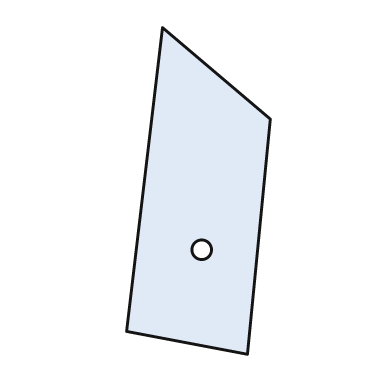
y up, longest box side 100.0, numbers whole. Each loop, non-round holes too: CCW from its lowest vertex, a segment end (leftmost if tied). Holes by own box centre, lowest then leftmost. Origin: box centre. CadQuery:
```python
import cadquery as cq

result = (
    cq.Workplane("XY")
    .moveTo(15.0, -50.0)
    .lineTo(22.0, 22.0)
    .lineTo(-11.0, 50.0)
    .lineTo(-22.0, -43.0)
    .close()
    .moveTo(1.0, -18.0)
    .circle(3.0)
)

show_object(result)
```